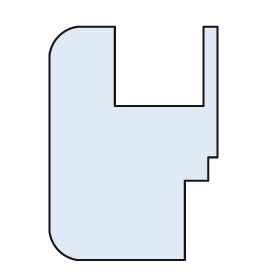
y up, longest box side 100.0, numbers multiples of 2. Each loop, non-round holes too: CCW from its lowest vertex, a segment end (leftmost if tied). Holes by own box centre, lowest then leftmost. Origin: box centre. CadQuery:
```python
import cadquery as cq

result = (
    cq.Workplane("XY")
    .moveTo(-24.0, -50.0)
    .lineTo(22.0, -50.0)
    .lineTo(22.0, -16.0)
    .lineTo(32.0, -16.0)
    .lineTo(32.0, -6.0)
    .lineTo(36.0, -6.0)
    .lineTo(36.0, 50.0)
    .lineTo(30.0, 50.0)
    .lineTo(30.0, 16.0)
    .lineTo(-8.0, 16.0)
    .lineTo(-8.0, 50.0)
    .lineTo(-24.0, 50.0)
    .threePointArc((-32.0, 46.0), (-36.0, 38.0))
    .lineTo(-36.0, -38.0)
    .threePointArc((-32.0, -46.0), (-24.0, -50.0))
    .close()
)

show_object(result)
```